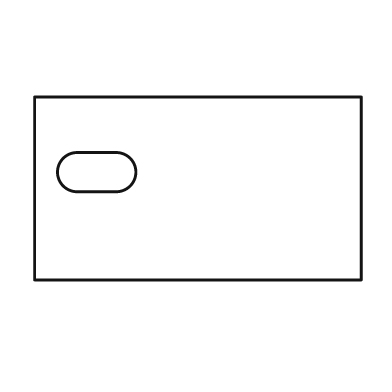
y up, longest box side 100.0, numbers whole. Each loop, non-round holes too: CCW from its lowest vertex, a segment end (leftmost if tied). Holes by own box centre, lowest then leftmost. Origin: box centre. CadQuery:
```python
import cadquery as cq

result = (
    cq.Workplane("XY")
    .moveTo(-50.0, -28.0)
    .lineTo(50.0, -28.0)
    .lineTo(50.0, 28.0)
    .lineTo(-50.0, 28.0)
    .close()
    .moveTo(-37.0, -1.0)
    .lineTo(-25.0, -1.0)
    .threePointArc((-19.0, 5.0), (-25.0, 11.0))
    .lineTo(-37.0, 11.0)
    .threePointArc((-43.0, 5.0), (-37.0, -1.0))
    .close()
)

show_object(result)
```